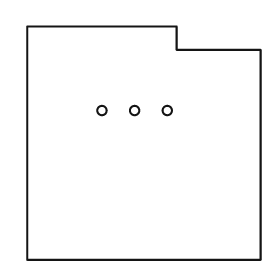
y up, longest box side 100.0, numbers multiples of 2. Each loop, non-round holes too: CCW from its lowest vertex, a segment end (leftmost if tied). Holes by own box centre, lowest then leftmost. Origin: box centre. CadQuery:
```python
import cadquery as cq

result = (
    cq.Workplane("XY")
    .moveTo(-50.0, -50.0)
    .lineTo(50.0, -50.0)
    .lineTo(50.0, 40.0)
    .lineTo(14.0, 40.0)
    .lineTo(14.0, 50.0)
    .lineTo(-50.0, 50.0)
    .close()
    .moveTo(-18.0, 14.0)
    .circle(2.0)
    .moveTo(-4.0, 14.0)
    .circle(2.0)
    .moveTo(10.0, 14.0)
    .circle(2.0)
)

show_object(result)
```